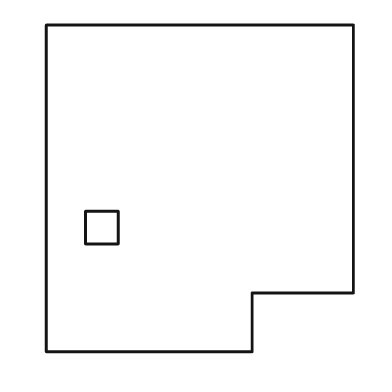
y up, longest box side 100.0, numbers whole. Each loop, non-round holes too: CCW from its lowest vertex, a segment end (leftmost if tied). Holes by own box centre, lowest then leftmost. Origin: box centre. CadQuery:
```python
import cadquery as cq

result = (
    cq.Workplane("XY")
    .moveTo(-47.0, -50.0)
    .lineTo(16.0, -50.0)
    .lineTo(16.0, -32.0)
    .lineTo(47.0, -32.0)
    .lineTo(47.0, 50.0)
    .lineTo(-47.0, 50.0)
    .close()
    .moveTo(-35.0, -17.0)
    .lineTo(-25.0, -17.0)
    .lineTo(-25.0, -7.0)
    .lineTo(-35.0, -7.0)
    .close()
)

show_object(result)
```